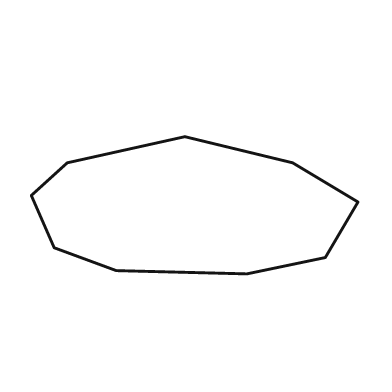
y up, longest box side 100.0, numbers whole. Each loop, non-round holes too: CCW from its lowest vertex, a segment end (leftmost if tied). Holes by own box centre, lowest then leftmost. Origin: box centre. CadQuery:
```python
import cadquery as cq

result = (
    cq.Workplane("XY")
    .moveTo(16.0, -21.0)
    .lineTo(40.0, -16.0)
    .lineTo(50.0, 1.0)
    .lineTo(30.0, 13.0)
    .lineTo(-3.0, 21.0)
    .lineTo(-39.0, 13.0)
    .lineTo(-50.0, 3.0)
    .lineTo(-43.0, -13.0)
    .lineTo(-24.0, -20.0)
    .close()
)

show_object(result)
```